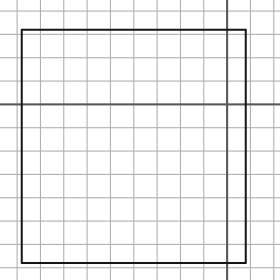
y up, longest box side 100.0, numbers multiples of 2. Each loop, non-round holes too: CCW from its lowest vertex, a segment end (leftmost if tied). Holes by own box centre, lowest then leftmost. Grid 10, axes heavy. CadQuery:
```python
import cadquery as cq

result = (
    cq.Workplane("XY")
    .moveTo(-88.0, -68.0)
    .lineTo(8.0, -68.0)
    .lineTo(8.0, 32.0)
    .lineTo(-88.0, 32.0)
    .close()
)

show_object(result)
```